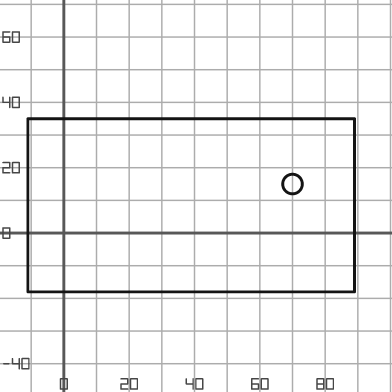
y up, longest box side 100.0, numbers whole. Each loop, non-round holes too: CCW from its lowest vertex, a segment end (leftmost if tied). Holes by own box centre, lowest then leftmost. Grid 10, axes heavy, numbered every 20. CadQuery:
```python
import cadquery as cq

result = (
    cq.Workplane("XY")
    .moveTo(-11.0, -18.0)
    .lineTo(89.0, -18.0)
    .lineTo(89.0, 35.0)
    .lineTo(-11.0, 35.0)
    .close()
    .moveTo(70.0, 15.0)
    .circle(3.0)
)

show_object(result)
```